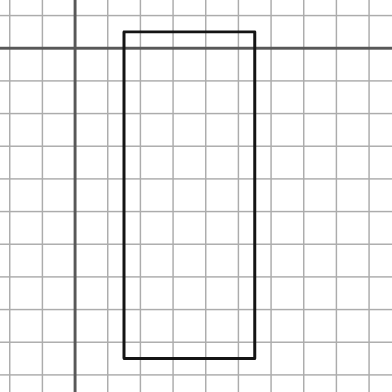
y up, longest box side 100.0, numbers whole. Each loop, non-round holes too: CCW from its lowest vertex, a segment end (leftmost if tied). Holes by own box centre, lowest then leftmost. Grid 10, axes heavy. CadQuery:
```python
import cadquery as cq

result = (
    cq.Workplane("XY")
    .moveTo(15.0, -95.0)
    .lineTo(55.0, -95.0)
    .lineTo(55.0, 5.0)
    .lineTo(15.0, 5.0)
    .close()
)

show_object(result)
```